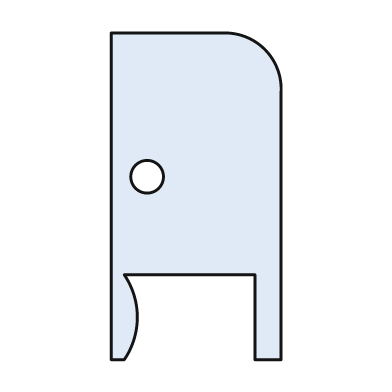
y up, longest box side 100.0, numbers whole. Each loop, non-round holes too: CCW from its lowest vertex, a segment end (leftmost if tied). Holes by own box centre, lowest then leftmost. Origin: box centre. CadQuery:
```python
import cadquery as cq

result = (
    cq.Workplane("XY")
    .moveTo(-26.0, -50.0)
    .lineTo(-22.0, -50.0)
    .threePointArc((-18.0, -37.0), (-22.0, -24.0))
    .lineTo(18.0, -24.0)
    .lineTo(18.0, -50.0)
    .lineTo(26.0, -50.0)
    .lineTo(26.0, 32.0)
    .threePointArc((21.0, 45.0), (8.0, 50.0))
    .lineTo(-26.0, 50.0)
    .close()
    .moveTo(-15.0, 6.0)
    .circle(5.0)
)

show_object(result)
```